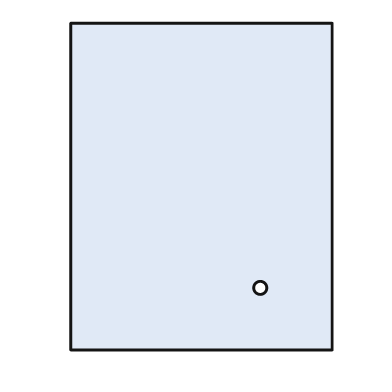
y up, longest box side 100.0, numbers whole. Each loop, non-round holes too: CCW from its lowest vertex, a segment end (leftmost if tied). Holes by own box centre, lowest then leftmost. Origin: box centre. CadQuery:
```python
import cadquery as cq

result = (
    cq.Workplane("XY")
    .moveTo(-40.0, -50.0)
    .lineTo(40.0, -50.0)
    .lineTo(40.0, 50.0)
    .lineTo(-40.0, 50.0)
    .close()
    .moveTo(18.0, -31.0)
    .circle(2.0)
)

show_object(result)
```